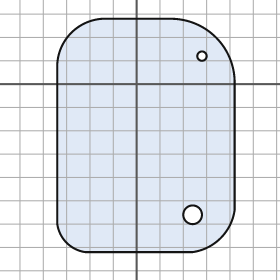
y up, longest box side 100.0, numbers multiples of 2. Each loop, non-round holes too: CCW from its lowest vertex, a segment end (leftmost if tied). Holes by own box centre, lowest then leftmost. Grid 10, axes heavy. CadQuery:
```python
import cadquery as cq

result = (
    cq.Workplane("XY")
    .moveTo(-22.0, -72.0)
    .lineTo(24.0, -72.0)
    .threePointArc((36.0, -66.0), (42.0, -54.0))
    .lineTo(42.0, 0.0)
    .threePointArc((34.0, 20.0), (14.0, 28.0))
    .lineTo(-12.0, 28.0)
    .threePointArc((-28.0, 22.0), (-34.0, 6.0))
    .lineTo(-34.0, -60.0)
    .threePointArc((-30.0, -68.0), (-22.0, -72.0))
    .close()
    .moveTo(24.0, -56.0)
    .circle(4.0)
    .moveTo(28.0, 12.0)
    .circle(2.0)
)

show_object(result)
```